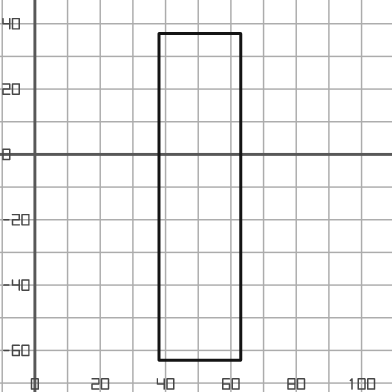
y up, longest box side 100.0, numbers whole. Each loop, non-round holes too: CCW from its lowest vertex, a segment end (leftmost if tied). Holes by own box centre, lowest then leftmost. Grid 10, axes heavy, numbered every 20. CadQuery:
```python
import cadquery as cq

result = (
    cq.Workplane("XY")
    .moveTo(38.0, -63.0)
    .lineTo(63.0, -63.0)
    .lineTo(63.0, 37.0)
    .lineTo(38.0, 37.0)
    .close()
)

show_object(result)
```